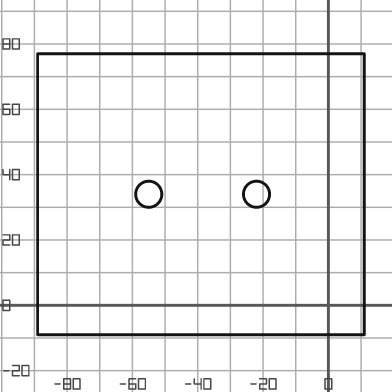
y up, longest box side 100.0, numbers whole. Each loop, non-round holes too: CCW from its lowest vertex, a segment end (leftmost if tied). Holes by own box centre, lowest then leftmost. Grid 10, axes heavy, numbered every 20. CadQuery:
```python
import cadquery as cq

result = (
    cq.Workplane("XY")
    .moveTo(-89.0, -9.0)
    .lineTo(11.0, -9.0)
    .lineTo(11.0, 77.0)
    .lineTo(-89.0, 77.0)
    .close()
    .moveTo(-55.0, 34.0)
    .circle(4.0)
    .moveTo(-22.0, 34.0)
    .circle(4.0)
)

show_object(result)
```